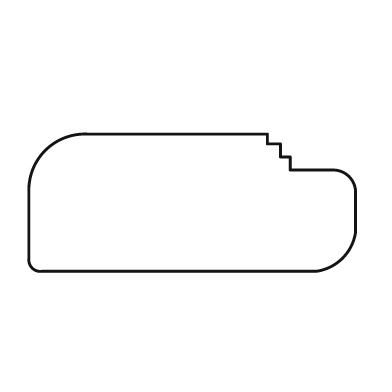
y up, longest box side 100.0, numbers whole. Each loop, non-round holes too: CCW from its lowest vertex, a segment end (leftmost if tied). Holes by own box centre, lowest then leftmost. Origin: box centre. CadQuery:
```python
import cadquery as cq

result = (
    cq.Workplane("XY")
    .moveTo(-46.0, -21.0)
    .lineTo(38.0, -21.0)
    .threePointArc((46.0, -17.0), (50.0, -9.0))
    .lineTo(50.0, 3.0)
    .threePointArc((48.0, 8.0), (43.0, 10.0))
    .lineTo(30.0, 10.0)
    .lineTo(30.0, 14.0)
    .lineTo(27.0, 14.0)
    .lineTo(27.0, 18.0)
    .lineTo(23.0, 18.0)
    .lineTo(23.0, 21.0)
    .lineTo(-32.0, 21.0)
    .threePointArc((-45.0, 16.0), (-50.0, 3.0))
    .lineTo(-50.0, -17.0)
    .threePointArc((-49.0, -20.0), (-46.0, -21.0))
    .close()
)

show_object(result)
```